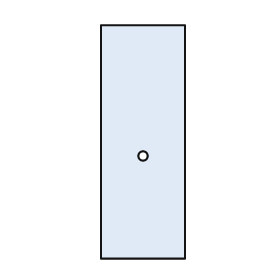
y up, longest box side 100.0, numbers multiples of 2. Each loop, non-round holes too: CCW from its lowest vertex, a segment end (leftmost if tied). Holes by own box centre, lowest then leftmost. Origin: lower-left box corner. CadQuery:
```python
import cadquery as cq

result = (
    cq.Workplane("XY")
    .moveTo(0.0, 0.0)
    .lineTo(36.0, 0.0)
    .lineTo(36.0, 100.0)
    .lineTo(0.0, 100.0)
    .close()
    .moveTo(18.0, 44.0)
    .circle(2.0)
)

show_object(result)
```